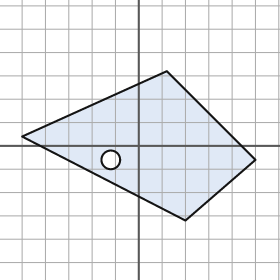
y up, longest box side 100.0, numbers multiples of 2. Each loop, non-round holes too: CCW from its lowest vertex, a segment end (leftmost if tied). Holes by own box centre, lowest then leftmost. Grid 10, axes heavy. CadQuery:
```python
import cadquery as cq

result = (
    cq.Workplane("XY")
    .moveTo(20.0, -32.0)
    .lineTo(50.0, -6.0)
    .lineTo(12.0, 32.0)
    .lineTo(-50.0, 4.0)
    .close()
    .moveTo(-12.0, -6.0)
    .circle(4.0)
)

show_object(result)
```